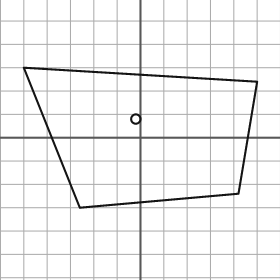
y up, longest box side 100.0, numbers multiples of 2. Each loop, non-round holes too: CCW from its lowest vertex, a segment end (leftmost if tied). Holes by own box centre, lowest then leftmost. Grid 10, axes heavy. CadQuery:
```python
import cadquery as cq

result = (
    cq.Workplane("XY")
    .moveTo(-26.0, -30.0)
    .lineTo(42.0, -24.0)
    .lineTo(50.0, 24.0)
    .lineTo(-50.0, 30.0)
    .close()
    .moveTo(-2.0, 8.0)
    .circle(2.0)
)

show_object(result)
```